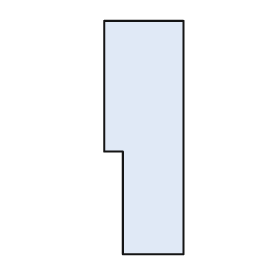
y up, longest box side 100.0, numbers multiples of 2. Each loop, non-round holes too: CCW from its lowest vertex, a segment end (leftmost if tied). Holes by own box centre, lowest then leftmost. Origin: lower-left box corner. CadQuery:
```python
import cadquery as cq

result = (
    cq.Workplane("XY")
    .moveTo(8.0, 0.0)
    .lineTo(34.0, 0.0)
    .lineTo(34.0, 100.0)
    .lineTo(0.0, 100.0)
    .lineTo(0.0, 44.0)
    .lineTo(8.0, 44.0)
    .close()
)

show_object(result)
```